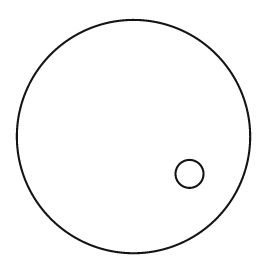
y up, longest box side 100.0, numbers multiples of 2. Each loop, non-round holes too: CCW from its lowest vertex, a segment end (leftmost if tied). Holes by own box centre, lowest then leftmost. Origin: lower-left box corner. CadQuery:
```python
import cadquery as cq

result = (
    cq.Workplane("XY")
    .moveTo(50.0, 50.0)
    .circle(50.0)
    .moveTo(74.0, 34.0)
    .circle(6.0)
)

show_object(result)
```